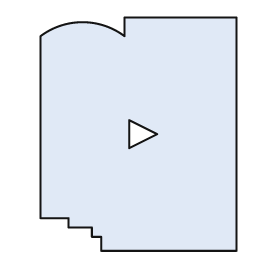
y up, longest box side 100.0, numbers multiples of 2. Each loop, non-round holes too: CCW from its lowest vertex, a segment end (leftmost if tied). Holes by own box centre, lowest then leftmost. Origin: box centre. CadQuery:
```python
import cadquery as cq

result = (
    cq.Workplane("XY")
    .moveTo(-16.0, -50.0)
    .lineTo(42.0, -50.0)
    .lineTo(42.0, 50.0)
    .lineTo(-6.0, 50.0)
    .lineTo(-6.0, 42.0)
    .threePointArc((-24.0, 48.0), (-42.0, 42.0))
    .lineTo(-42.0, -36.0)
    .lineTo(-30.0, -36.0)
    .lineTo(-30.0, -40.0)
    .lineTo(-20.0, -40.0)
    .lineTo(-20.0, -44.0)
    .lineTo(-16.0, -44.0)
    .close()
    .moveTo(-4.0, -6.0)
    .lineTo(8.0, 0.0)
    .lineTo(-4.0, 6.0)
    .close()
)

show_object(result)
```